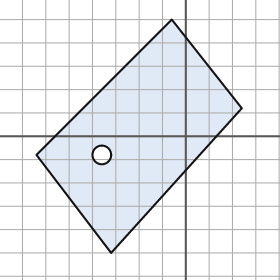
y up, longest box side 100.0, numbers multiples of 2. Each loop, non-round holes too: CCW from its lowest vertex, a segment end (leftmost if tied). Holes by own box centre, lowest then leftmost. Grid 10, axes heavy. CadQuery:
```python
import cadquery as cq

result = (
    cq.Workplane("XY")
    .moveTo(-32.0, -50.0)
    .lineTo(24.0, 12.0)
    .lineTo(-6.0, 50.0)
    .lineTo(-64.0, -8.0)
    .close()
    .moveTo(-36.0, -8.0)
    .circle(4.0)
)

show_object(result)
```